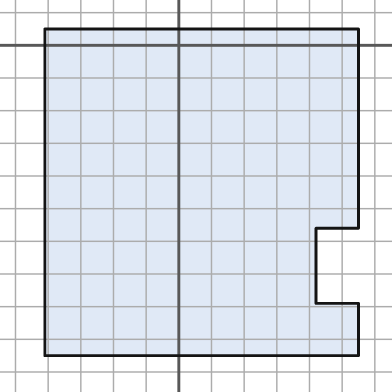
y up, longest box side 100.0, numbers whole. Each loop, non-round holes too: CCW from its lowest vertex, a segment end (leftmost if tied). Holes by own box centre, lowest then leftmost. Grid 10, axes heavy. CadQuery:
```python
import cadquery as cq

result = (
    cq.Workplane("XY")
    .moveTo(-41.0, -95.0)
    .lineTo(55.0, -95.0)
    .lineTo(55.0, -79.0)
    .lineTo(42.0, -79.0)
    .lineTo(42.0, -56.0)
    .lineTo(55.0, -56.0)
    .lineTo(55.0, 5.0)
    .lineTo(-41.0, 5.0)
    .close()
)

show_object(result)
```